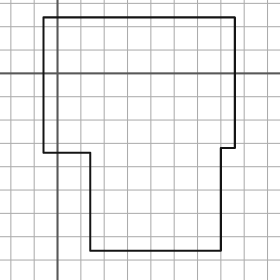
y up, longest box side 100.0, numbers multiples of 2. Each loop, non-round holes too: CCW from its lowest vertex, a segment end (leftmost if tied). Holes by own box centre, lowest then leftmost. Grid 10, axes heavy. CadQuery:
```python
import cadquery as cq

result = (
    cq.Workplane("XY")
    .moveTo(14.0, -76.0)
    .lineTo(70.0, -76.0)
    .lineTo(70.0, -32.0)
    .lineTo(76.0, -32.0)
    .lineTo(76.0, 24.0)
    .lineTo(-6.0, 24.0)
    .lineTo(-6.0, -34.0)
    .lineTo(14.0, -34.0)
    .close()
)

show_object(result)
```